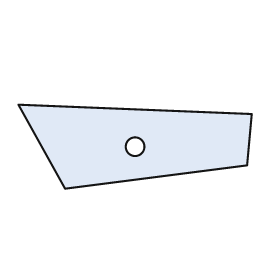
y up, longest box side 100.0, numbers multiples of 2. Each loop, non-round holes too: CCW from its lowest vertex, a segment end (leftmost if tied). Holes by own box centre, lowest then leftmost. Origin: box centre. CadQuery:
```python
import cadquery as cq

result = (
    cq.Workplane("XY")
    .moveTo(-30.0, -18.0)
    .lineTo(48.0, -8.0)
    .lineTo(50.0, 14.0)
    .lineTo(-50.0, 18.0)
    .close()
    .moveTo(0.0, 0.0)
    .circle(4.0)
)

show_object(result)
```